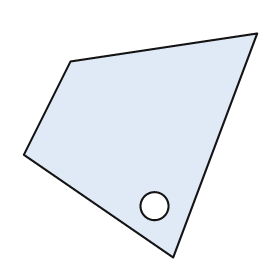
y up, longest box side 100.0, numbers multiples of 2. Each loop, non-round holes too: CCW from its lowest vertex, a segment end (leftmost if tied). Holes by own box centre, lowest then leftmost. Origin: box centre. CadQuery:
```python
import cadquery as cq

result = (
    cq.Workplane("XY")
    .moveTo(14.0, -48.0)
    .lineTo(50.0, 48.0)
    .lineTo(-30.0, 36.0)
    .lineTo(-50.0, -4.0)
    .close()
    .moveTo(6.0, -26.0)
    .circle(6.0)
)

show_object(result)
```